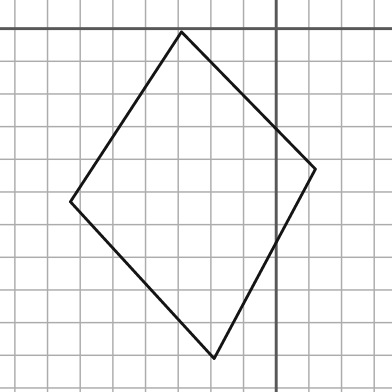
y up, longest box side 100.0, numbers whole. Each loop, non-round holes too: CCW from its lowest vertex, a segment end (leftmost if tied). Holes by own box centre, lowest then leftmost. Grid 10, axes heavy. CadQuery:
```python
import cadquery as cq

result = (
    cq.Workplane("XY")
    .moveTo(-19.0, -101.0)
    .lineTo(12.0, -43.0)
    .lineTo(-29.0, -1.0)
    .lineTo(-63.0, -53.0)
    .close()
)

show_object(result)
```